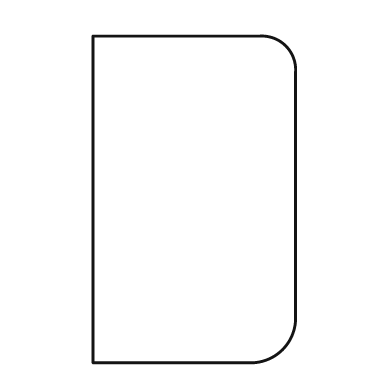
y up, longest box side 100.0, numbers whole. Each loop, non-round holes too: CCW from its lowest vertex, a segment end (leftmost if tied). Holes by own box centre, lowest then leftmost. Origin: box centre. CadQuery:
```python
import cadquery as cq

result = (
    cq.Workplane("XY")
    .moveTo(-31.0, -50.0)
    .lineTo(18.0, -50.0)
    .threePointArc((27.0, -46.0), (31.0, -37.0))
    .lineTo(31.0, 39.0)
    .threePointArc((28.0, 47.0), (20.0, 50.0))
    .lineTo(-31.0, 50.0)
    .close()
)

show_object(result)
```